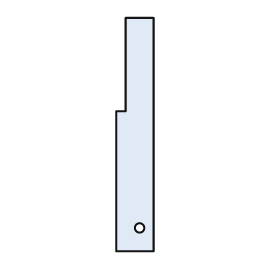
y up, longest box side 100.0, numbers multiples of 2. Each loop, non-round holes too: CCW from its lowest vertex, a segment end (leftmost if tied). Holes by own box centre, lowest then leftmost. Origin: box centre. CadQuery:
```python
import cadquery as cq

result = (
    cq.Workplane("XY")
    .moveTo(-8.0, -50.0)
    .lineTo(8.0, -50.0)
    .lineTo(8.0, 50.0)
    .lineTo(-4.0, 50.0)
    .lineTo(-4.0, 10.0)
    .lineTo(-8.0, 10.0)
    .close()
    .moveTo(2.0, -40.0)
    .circle(2.0)
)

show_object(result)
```